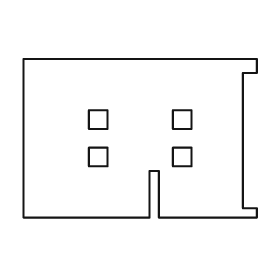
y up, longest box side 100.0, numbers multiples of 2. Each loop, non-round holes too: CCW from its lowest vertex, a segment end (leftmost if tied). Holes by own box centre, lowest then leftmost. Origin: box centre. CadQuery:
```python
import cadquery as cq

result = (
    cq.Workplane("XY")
    .moveTo(-50.0, -34.0)
    .lineTo(4.0, -34.0)
    .lineTo(4.0, -14.0)
    .lineTo(8.0, -14.0)
    .lineTo(8.0, -34.0)
    .lineTo(50.0, -34.0)
    .lineTo(50.0, -30.0)
    .lineTo(44.0, -30.0)
    .lineTo(44.0, 28.0)
    .lineTo(50.0, 28.0)
    .lineTo(50.0, 34.0)
    .lineTo(-50.0, 34.0)
    .close()
    .moveTo(-22.0, -12.0)
    .lineTo(-14.0, -12.0)
    .lineTo(-14.0, -4.0)
    .lineTo(-22.0, -4.0)
    .close()
    .moveTo(14.0, -12.0)
    .lineTo(22.0, -12.0)
    .lineTo(22.0, -4.0)
    .lineTo(14.0, -4.0)
    .close()
    .moveTo(-22.0, 4.0)
    .lineTo(-14.0, 4.0)
    .lineTo(-14.0, 12.0)
    .lineTo(-22.0, 12.0)
    .close()
    .moveTo(14.0, 4.0)
    .lineTo(22.0, 4.0)
    .lineTo(22.0, 12.0)
    .lineTo(14.0, 12.0)
    .close()
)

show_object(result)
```